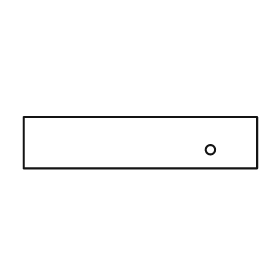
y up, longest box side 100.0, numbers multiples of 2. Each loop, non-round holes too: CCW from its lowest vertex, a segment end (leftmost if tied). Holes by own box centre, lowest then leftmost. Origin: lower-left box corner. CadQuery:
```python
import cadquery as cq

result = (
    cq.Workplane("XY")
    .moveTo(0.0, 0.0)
    .lineTo(100.0, 0.0)
    .lineTo(100.0, 22.0)
    .lineTo(0.0, 22.0)
    .close()
    .moveTo(80.0, 8.0)
    .circle(2.0)
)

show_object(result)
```